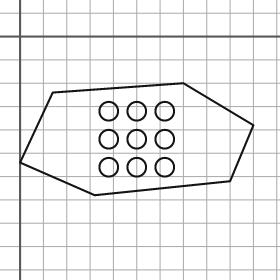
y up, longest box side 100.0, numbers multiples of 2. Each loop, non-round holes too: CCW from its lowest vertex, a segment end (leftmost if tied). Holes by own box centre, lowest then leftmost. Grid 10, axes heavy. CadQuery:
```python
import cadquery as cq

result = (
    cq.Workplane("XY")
    .moveTo(32.0, -68.0)
    .lineTo(90.0, -62.0)
    .lineTo(100.0, -38.0)
    .lineTo(70.0, -20.0)
    .lineTo(14.0, -24.0)
    .lineTo(0.0, -54.0)
    .close()
    .moveTo(38.0, -56.0)
    .circle(4.0)
    .moveTo(50.0, -56.0)
    .circle(4.0)
    .moveTo(62.0, -56.0)
    .circle(4.0)
    .moveTo(38.0, -44.0)
    .circle(4.0)
    .moveTo(50.0, -44.0)
    .circle(4.0)
    .moveTo(62.0, -44.0)
    .circle(4.0)
    .moveTo(38.0, -32.0)
    .circle(4.0)
    .moveTo(50.0, -32.0)
    .circle(4.0)
    .moveTo(62.0, -32.0)
    .circle(4.0)
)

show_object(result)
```